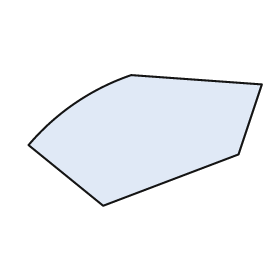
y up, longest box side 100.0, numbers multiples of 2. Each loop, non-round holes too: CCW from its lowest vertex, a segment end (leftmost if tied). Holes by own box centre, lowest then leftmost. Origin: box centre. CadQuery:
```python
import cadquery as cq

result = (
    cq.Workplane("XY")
    .moveTo(-18.0, -28.0)
    .lineTo(40.0, -6.0)
    .lineTo(50.0, 24.0)
    .lineTo(-6.0, 28.0)
    .threePointArc((-30.0, 16.0), (-50.0, -2.0))
    .close()
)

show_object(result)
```